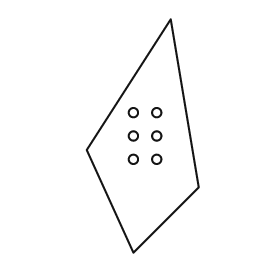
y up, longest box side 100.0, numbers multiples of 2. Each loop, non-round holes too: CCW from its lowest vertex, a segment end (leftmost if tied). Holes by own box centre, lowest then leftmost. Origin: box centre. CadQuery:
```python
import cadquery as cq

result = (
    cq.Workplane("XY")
    .moveTo(-4.0, -50.0)
    .lineTo(24.0, -22.0)
    .lineTo(12.0, 50.0)
    .lineTo(-24.0, -6.0)
    .close()
    .moveTo(-4.0, -10.0)
    .circle(2.0)
    .moveTo(6.0, -10.0)
    .circle(2.0)
    .moveTo(-4.0, 0.0)
    .circle(2.0)
    .moveTo(6.0, 0.0)
    .circle(2.0)
    .moveTo(-4.0, 10.0)
    .circle(2.0)
    .moveTo(6.0, 10.0)
    .circle(2.0)
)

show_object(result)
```